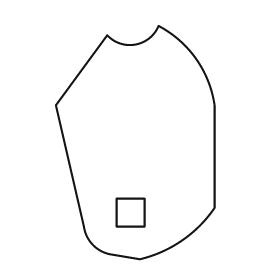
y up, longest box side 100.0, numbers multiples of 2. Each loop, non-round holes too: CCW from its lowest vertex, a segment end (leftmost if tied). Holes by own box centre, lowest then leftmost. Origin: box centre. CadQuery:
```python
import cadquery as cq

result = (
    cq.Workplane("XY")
    .moveTo(2.0, -50.0)
    .threePointArc((20.0, -42.0), (34.0, -28.0))
    .lineTo(34.0, 16.0)
    .threePointArc((26.0, 36.0), (10.0, 50.0))
    .threePointArc((0.0, 42.0), (-12.0, 46.0))
    .lineTo(-34.0, 16.0)
    .lineTo(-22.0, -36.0)
    .threePointArc((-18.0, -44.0), (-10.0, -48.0))
    .close()
    .moveTo(-8.0, -36.0)
    .lineTo(4.0, -36.0)
    .lineTo(4.0, -24.0)
    .lineTo(-8.0, -24.0)
    .close()
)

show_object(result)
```